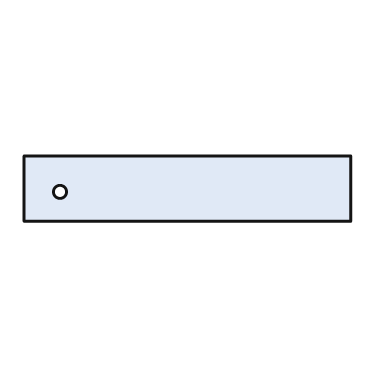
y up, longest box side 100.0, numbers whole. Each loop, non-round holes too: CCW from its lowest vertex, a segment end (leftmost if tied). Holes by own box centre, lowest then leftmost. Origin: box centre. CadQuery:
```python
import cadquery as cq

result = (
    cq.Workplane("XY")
    .moveTo(-50.0, -10.0)
    .lineTo(50.0, -10.0)
    .lineTo(50.0, 10.0)
    .lineTo(-50.0, 10.0)
    .close()
    .moveTo(-39.0, -1.0)
    .circle(2.0)
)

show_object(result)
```